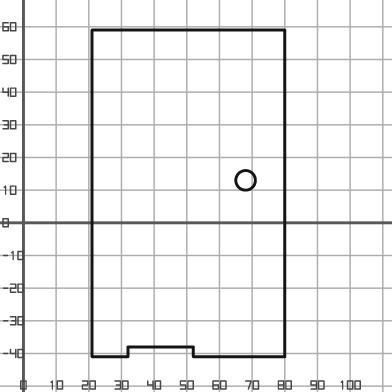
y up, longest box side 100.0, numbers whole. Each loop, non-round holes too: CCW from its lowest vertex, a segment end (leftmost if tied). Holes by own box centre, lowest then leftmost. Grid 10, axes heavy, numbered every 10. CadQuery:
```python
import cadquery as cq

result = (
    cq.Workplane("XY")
    .moveTo(21.0, -41.0)
    .lineTo(32.0, -41.0)
    .lineTo(32.0, -38.0)
    .lineTo(52.0, -38.0)
    .lineTo(52.0, -41.0)
    .lineTo(80.0, -41.0)
    .lineTo(80.0, 59.0)
    .lineTo(21.0, 59.0)
    .close()
    .moveTo(68.0, 13.0)
    .circle(3.0)
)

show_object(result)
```